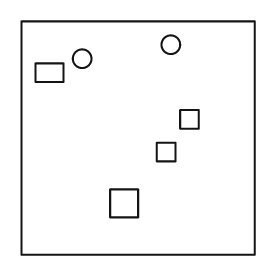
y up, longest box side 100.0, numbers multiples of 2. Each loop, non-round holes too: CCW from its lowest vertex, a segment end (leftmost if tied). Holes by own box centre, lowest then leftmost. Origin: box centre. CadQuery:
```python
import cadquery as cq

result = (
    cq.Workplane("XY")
    .moveTo(-50.0, -50.0)
    .lineTo(50.0, -50.0)
    .lineTo(50.0, 50.0)
    .lineTo(-50.0, 50.0)
    .close()
    .moveTo(-12.0, -34.0)
    .lineTo(0.0, -34.0)
    .lineTo(0.0, -22.0)
    .lineTo(-12.0, -22.0)
    .close()
    .moveTo(8.0, -10.0)
    .lineTo(16.0, -10.0)
    .lineTo(16.0, -2.0)
    .lineTo(8.0, -2.0)
    .close()
    .moveTo(18.0, 4.0)
    .lineTo(26.0, 4.0)
    .lineTo(26.0, 12.0)
    .lineTo(18.0, 12.0)
    .close()
    .moveTo(-44.0, 24.0)
    .lineTo(-32.0, 24.0)
    .lineTo(-32.0, 32.0)
    .lineTo(-44.0, 32.0)
    .close()
    .moveTo(-24.0, 34.0)
    .circle(4.0)
    .moveTo(14.0, 40.0)
    .circle(4.0)
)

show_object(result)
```